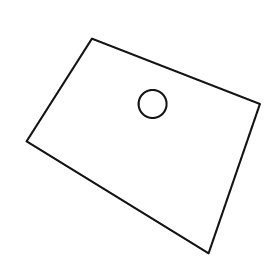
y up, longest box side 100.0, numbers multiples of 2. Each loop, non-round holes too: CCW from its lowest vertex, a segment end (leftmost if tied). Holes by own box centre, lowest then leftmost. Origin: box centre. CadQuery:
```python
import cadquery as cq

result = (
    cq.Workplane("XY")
    .moveTo(28.0, -46.0)
    .lineTo(50.0, 18.0)
    .lineTo(-22.0, 46.0)
    .lineTo(-50.0, 2.0)
    .close()
    .moveTo(4.0, 18.0)
    .circle(6.0)
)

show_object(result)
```